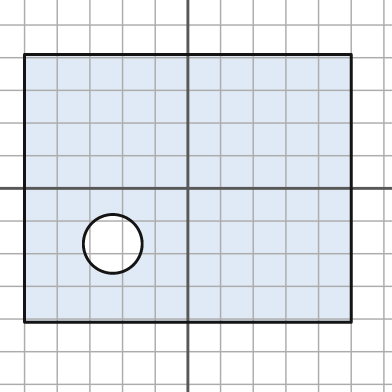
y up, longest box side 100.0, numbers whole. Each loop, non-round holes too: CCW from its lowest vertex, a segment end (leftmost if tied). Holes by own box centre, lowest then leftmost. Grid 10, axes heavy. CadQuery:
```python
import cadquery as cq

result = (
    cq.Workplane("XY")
    .moveTo(-50.0, -41.0)
    .lineTo(50.0, -41.0)
    .lineTo(50.0, 41.0)
    .lineTo(-50.0, 41.0)
    .close()
    .moveTo(-23.0, -17.0)
    .circle(9.0)
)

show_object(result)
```